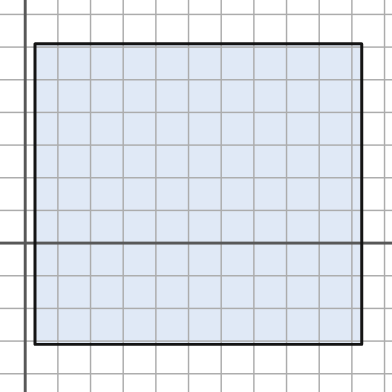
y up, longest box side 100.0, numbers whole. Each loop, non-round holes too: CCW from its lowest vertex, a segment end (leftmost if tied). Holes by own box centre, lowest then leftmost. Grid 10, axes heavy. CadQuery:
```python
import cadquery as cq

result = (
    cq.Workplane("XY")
    .moveTo(3.0, -31.0)
    .lineTo(103.0, -31.0)
    .lineTo(103.0, 61.0)
    .lineTo(3.0, 61.0)
    .close()
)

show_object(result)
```